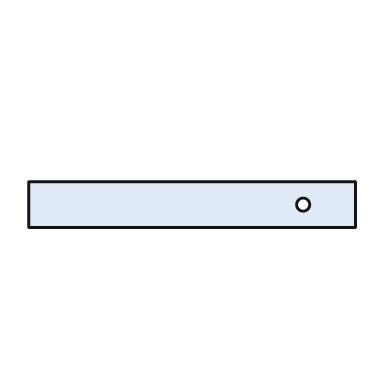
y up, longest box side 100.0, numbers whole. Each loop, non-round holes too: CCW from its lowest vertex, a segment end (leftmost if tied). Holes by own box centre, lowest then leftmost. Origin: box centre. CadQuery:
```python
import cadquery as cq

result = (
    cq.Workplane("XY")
    .moveTo(-50.0, -7.0)
    .lineTo(50.0, -7.0)
    .lineTo(50.0, 7.0)
    .lineTo(-50.0, 7.0)
    .close()
    .moveTo(34.0, 0.0)
    .circle(2.0)
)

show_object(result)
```